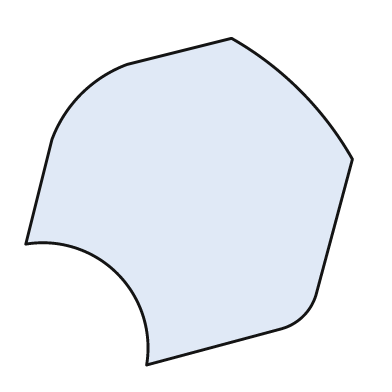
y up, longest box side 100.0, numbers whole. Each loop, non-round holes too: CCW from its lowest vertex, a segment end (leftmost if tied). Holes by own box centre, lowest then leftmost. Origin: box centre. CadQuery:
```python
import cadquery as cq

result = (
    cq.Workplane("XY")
    .moveTo(-13.0, -50.0)
    .lineTo(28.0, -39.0)
    .threePointArc((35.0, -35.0), (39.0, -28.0))
    .lineTo(50.0, 13.0)
    .threePointArc((34.0, 34.0), (13.0, 50.0))
    .lineTo(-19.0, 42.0)
    .threePointArc((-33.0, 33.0), (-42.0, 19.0))
    .lineTo(-50.0, -13.0)
    .threePointArc((-22.0, -22.0), (-13.0, -50.0))
    .close()
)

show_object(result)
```